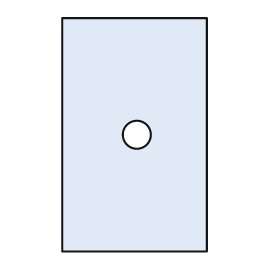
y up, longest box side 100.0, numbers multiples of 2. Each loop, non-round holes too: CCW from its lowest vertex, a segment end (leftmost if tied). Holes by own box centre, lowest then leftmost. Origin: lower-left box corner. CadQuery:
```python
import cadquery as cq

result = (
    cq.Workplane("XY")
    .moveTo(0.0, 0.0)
    .lineTo(62.0, 0.0)
    .lineTo(62.0, 100.0)
    .lineTo(0.0, 100.0)
    .close()
    .moveTo(32.0, 50.0)
    .circle(6.0)
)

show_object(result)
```